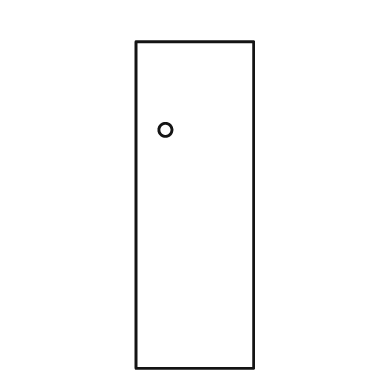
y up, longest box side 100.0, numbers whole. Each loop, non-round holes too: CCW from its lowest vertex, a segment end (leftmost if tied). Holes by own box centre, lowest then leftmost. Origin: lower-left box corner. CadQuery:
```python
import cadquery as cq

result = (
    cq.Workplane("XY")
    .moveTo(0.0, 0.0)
    .lineTo(36.0, 0.0)
    .lineTo(36.0, 100.0)
    .lineTo(0.0, 100.0)
    .close()
    .moveTo(9.0, 73.0)
    .circle(2.0)
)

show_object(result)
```